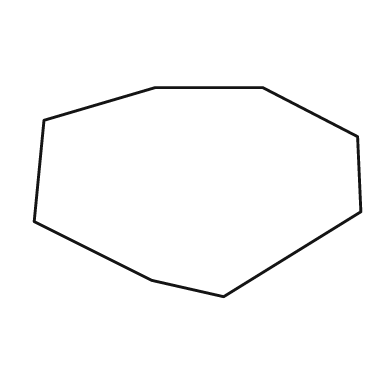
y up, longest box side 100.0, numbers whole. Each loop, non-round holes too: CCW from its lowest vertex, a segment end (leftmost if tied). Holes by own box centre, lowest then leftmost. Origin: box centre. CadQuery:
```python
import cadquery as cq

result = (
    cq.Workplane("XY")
    .moveTo(8.0, -32.0)
    .lineTo(50.0, -6.0)
    .lineTo(49.0, 17.0)
    .lineTo(20.0, 32.0)
    .lineTo(-13.0, 32.0)
    .lineTo(-47.0, 22.0)
    .lineTo(-50.0, -9.0)
    .lineTo(-14.0, -27.0)
    .close()
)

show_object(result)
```